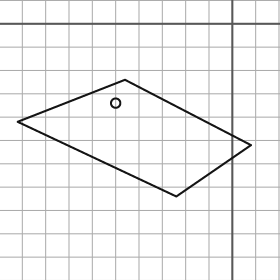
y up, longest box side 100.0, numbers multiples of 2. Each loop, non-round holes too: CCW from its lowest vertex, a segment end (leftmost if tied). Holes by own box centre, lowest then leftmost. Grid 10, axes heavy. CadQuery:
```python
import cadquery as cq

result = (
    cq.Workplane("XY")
    .moveTo(-24.0, -74.0)
    .lineTo(8.0, -52.0)
    .lineTo(-46.0, -24.0)
    .lineTo(-92.0, -42.0)
    .close()
    .moveTo(-50.0, -34.0)
    .circle(2.0)
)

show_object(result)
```